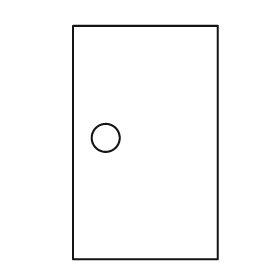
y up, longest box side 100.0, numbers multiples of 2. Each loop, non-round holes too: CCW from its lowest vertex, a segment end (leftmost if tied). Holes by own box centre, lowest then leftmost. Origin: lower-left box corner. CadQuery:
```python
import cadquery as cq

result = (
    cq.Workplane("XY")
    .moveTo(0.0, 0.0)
    .lineTo(62.0, 0.0)
    .lineTo(62.0, 100.0)
    .lineTo(0.0, 100.0)
    .close()
    .moveTo(14.0, 52.0)
    .circle(6.0)
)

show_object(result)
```